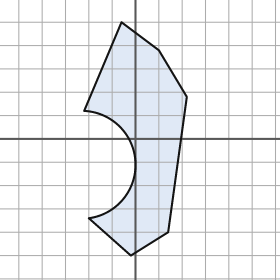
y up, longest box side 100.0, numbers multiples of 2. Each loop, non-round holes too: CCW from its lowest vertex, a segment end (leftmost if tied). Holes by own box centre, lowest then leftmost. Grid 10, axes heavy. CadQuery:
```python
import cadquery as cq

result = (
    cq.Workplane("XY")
    .moveTo(-2.0, -50.0)
    .lineTo(14.0, -40.0)
    .lineTo(22.0, 18.0)
    .lineTo(10.0, 38.0)
    .lineTo(-6.0, 50.0)
    .lineTo(-22.0, 12.0)
    .threePointArc((0.0, -10.0), (-20.0, -34.0))
    .close()
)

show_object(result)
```